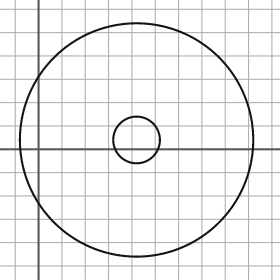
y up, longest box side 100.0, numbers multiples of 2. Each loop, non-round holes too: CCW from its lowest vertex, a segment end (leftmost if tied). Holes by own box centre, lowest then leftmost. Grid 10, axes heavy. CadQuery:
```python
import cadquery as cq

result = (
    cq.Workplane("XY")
    .moveTo(42.0, 4.0)
    .circle(50.0)
    .moveTo(42.0, 4.0)
    .circle(10.0)
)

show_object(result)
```